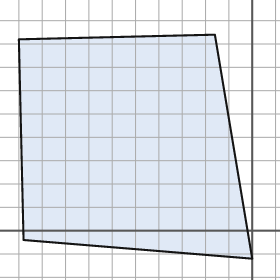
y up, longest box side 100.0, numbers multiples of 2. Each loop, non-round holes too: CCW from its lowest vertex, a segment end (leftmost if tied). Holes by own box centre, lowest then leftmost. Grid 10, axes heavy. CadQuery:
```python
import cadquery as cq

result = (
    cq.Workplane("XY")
    .moveTo(0.0, -12.0)
    .lineTo(-16.0, 84.0)
    .lineTo(-100.0, 82.0)
    .lineTo(-98.0, -4.0)
    .close()
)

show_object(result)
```